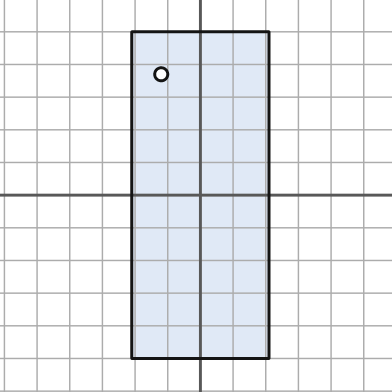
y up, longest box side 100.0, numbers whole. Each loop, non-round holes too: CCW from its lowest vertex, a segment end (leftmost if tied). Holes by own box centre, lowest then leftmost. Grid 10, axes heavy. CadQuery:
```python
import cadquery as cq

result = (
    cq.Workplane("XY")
    .moveTo(-21.0, -50.0)
    .lineTo(21.0, -50.0)
    .lineTo(21.0, 50.0)
    .lineTo(-21.0, 50.0)
    .close()
    .moveTo(-12.0, 37.0)
    .circle(2.0)
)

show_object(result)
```